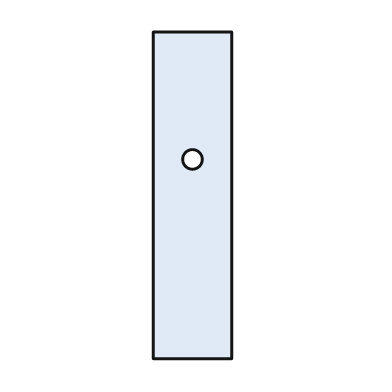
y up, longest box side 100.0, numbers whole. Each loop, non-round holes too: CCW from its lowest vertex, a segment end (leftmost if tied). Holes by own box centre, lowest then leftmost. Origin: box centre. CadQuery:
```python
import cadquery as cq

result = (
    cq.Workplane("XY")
    .moveTo(-12.0, -50.0)
    .lineTo(12.0, -50.0)
    .lineTo(12.0, 50.0)
    .lineTo(-12.0, 50.0)
    .close()
    .moveTo(0.0, 11.0)
    .circle(3.0)
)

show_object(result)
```